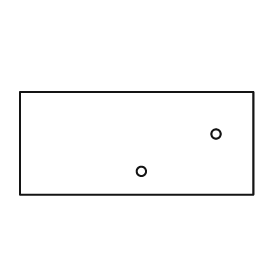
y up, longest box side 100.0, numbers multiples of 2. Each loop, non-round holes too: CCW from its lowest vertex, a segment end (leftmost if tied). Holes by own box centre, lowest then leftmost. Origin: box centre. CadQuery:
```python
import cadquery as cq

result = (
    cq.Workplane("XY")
    .moveTo(-50.0, -22.0)
    .lineTo(50.0, -22.0)
    .lineTo(50.0, 22.0)
    .lineTo(-50.0, 22.0)
    .close()
    .moveTo(2.0, -12.0)
    .circle(2.0)
    .moveTo(34.0, 4.0)
    .circle(2.0)
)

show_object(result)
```